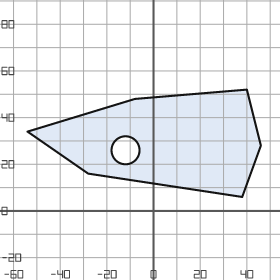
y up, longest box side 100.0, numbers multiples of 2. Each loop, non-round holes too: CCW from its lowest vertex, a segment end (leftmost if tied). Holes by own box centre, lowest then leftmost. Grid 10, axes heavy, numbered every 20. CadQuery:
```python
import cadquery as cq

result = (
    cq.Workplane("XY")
    .moveTo(38.0, 6.0)
    .lineTo(46.0, 28.0)
    .lineTo(40.0, 52.0)
    .lineTo(-8.0, 48.0)
    .lineTo(-54.0, 34.0)
    .lineTo(-28.0, 16.0)
    .close()
    .moveTo(-12.0, 26.0)
    .circle(6.0)
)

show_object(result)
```